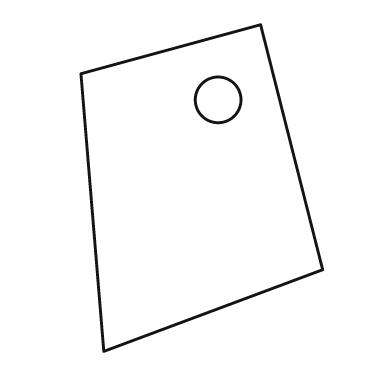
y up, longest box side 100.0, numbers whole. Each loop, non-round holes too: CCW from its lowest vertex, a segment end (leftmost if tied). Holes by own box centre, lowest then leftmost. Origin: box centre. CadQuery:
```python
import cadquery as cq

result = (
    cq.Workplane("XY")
    .moveTo(-30.0, -50.0)
    .lineTo(37.0, -25.0)
    .lineTo(18.0, 50.0)
    .lineTo(-37.0, 35.0)
    .close()
    .moveTo(5.0, 27.0)
    .circle(7.0)
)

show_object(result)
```